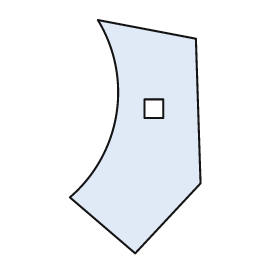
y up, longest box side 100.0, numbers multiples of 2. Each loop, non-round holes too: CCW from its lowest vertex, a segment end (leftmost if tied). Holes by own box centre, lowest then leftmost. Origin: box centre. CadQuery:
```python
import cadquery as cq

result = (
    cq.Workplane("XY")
    .moveTo(0.0, -50.0)
    .lineTo(28.0, -20.0)
    .lineTo(26.0, 42.0)
    .lineTo(-16.0, 50.0)
    .threePointArc((-8.0, 10.0), (-28.0, -26.0))
    .close()
    .moveTo(4.0, 8.0)
    .lineTo(12.0, 8.0)
    .lineTo(12.0, 16.0)
    .lineTo(4.0, 16.0)
    .close()
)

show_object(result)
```